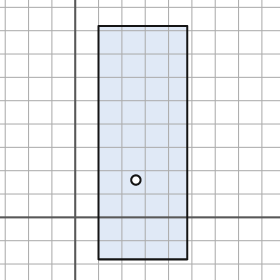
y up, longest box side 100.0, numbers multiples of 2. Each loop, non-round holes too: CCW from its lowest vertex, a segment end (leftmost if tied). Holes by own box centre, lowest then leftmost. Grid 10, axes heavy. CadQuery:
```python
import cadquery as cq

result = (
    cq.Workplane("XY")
    .moveTo(10.0, -18.0)
    .lineTo(48.0, -18.0)
    .lineTo(48.0, 82.0)
    .lineTo(10.0, 82.0)
    .close()
    .moveTo(26.0, 16.0)
    .circle(2.0)
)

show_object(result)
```